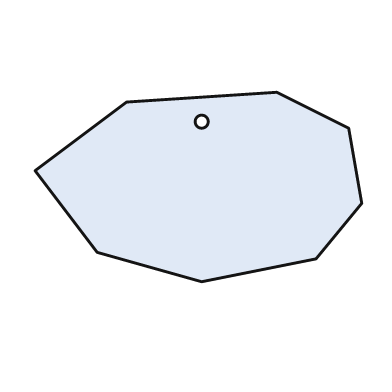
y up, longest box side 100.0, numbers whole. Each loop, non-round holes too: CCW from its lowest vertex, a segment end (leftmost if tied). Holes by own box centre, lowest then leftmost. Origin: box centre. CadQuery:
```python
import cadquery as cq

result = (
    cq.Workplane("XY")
    .moveTo(1.0, -29.0)
    .lineTo(36.0, -22.0)
    .lineTo(50.0, -5.0)
    .lineTo(46.0, 18.0)
    .lineTo(24.0, 29.0)
    .lineTo(-22.0, 26.0)
    .lineTo(-50.0, 5.0)
    .lineTo(-31.0, -20.0)
    .close()
    .moveTo(1.0, 20.0)
    .circle(2.0)
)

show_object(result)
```